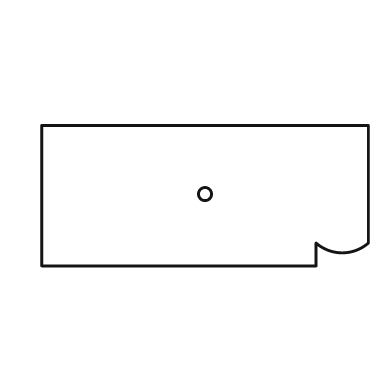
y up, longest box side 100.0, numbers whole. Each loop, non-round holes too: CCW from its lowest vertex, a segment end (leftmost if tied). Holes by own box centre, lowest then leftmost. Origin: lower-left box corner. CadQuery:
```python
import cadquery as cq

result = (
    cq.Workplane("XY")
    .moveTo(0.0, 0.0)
    .lineTo(84.0, 0.0)
    .lineTo(84.0, 7.0)
    .threePointArc((92.0, 4.0), (100.0, 7.0))
    .lineTo(100.0, 43.0)
    .lineTo(0.0, 43.0)
    .close()
    .moveTo(50.0, 22.0)
    .circle(2.0)
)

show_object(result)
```